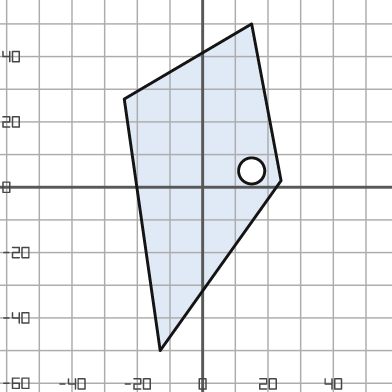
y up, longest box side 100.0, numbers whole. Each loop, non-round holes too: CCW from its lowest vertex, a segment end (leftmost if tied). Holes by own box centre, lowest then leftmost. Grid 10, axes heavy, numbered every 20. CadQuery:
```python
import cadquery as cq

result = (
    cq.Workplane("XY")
    .moveTo(-13.0, -50.0)
    .lineTo(24.0, 2.0)
    .lineTo(15.0, 50.0)
    .lineTo(-24.0, 27.0)
    .close()
    .moveTo(15.0, 5.0)
    .circle(4.0)
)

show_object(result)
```